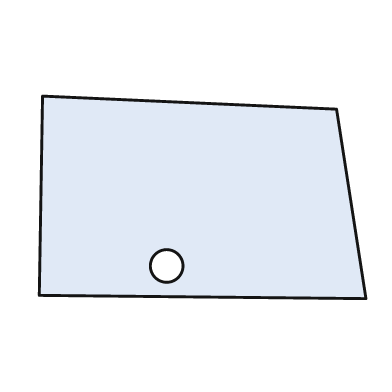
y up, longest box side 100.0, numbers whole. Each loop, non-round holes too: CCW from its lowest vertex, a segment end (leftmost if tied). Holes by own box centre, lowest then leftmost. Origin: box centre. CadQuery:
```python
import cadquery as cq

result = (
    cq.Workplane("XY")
    .moveTo(50.0, -31.0)
    .lineTo(41.0, 27.0)
    .lineTo(-49.0, 31.0)
    .lineTo(-50.0, -30.0)
    .close()
    .moveTo(-11.0, -21.0)
    .circle(5.0)
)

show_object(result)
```